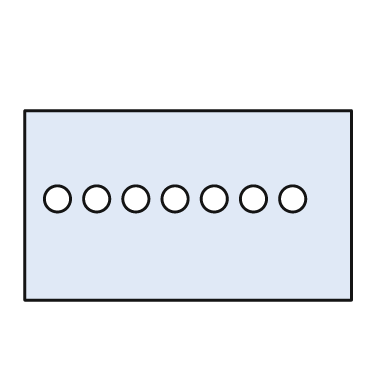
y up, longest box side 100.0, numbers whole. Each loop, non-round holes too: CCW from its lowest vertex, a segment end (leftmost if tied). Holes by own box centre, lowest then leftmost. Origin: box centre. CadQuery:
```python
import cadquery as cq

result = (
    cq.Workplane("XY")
    .moveTo(-50.0, -29.0)
    .lineTo(50.0, -29.0)
    .lineTo(50.0, 29.0)
    .lineTo(-50.0, 29.0)
    .close()
    .moveTo(-40.0, 2.0)
    .circle(4.0)
    .moveTo(-28.0, 2.0)
    .circle(4.0)
    .moveTo(-16.0, 2.0)
    .circle(4.0)
    .moveTo(-4.0, 2.0)
    .circle(4.0)
    .moveTo(8.0, 2.0)
    .circle(4.0)
    .moveTo(20.0, 2.0)
    .circle(4.0)
    .moveTo(32.0, 2.0)
    .circle(4.0)
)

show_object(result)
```